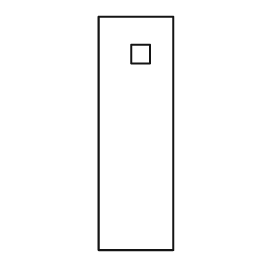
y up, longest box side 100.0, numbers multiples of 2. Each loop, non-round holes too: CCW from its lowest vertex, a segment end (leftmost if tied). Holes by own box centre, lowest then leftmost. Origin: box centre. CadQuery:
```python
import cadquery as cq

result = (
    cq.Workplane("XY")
    .moveTo(-16.0, -50.0)
    .lineTo(16.0, -50.0)
    .lineTo(16.0, 50.0)
    .lineTo(-16.0, 50.0)
    .close()
    .moveTo(-2.0, 30.0)
    .lineTo(6.0, 30.0)
    .lineTo(6.0, 38.0)
    .lineTo(-2.0, 38.0)
    .close()
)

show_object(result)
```